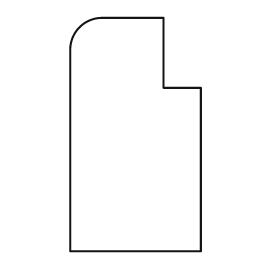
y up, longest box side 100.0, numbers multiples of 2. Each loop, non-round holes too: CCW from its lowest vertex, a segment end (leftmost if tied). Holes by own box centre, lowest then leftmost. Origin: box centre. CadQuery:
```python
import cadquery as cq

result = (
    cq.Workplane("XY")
    .moveTo(-28.0, -50.0)
    .lineTo(28.0, -50.0)
    .lineTo(28.0, 20.0)
    .lineTo(12.0, 20.0)
    .lineTo(12.0, 50.0)
    .lineTo(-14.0, 50.0)
    .threePointArc((-24.0, 46.0), (-28.0, 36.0))
    .close()
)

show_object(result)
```